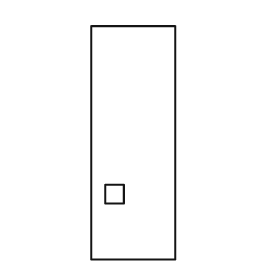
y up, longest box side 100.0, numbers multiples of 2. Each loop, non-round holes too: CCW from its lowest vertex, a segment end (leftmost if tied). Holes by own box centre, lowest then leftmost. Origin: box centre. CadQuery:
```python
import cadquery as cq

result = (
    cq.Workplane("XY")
    .moveTo(-18.0, -50.0)
    .lineTo(18.0, -50.0)
    .lineTo(18.0, 50.0)
    .lineTo(-18.0, 50.0)
    .close()
    .moveTo(-12.0, -26.0)
    .lineTo(-4.0, -26.0)
    .lineTo(-4.0, -18.0)
    .lineTo(-12.0, -18.0)
    .close()
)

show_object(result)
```